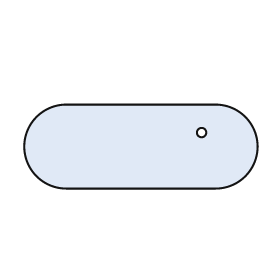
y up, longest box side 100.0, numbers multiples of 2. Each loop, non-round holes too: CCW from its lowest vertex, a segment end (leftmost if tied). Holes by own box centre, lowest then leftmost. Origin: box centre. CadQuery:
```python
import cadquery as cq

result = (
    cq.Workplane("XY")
    .moveTo(-32.0, -18.0)
    .lineTo(32.0, -18.0)
    .threePointArc((50.0, 0.0), (32.0, 18.0))
    .lineTo(-32.0, 18.0)
    .threePointArc((-50.0, 0.0), (-32.0, -18.0))
    .close()
    .moveTo(26.0, 6.0)
    .circle(2.0)
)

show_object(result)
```